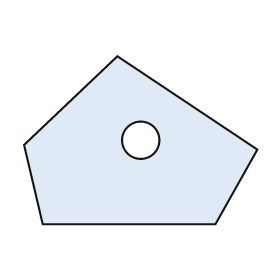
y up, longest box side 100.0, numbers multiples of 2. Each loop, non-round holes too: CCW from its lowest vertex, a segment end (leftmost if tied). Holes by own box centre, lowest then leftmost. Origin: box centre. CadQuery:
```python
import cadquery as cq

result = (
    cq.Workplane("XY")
    .moveTo(-42.0, -36.0)
    .lineTo(32.0, -36.0)
    .lineTo(50.0, -4.0)
    .lineTo(-10.0, 36.0)
    .lineTo(-50.0, -2.0)
    .close()
    .moveTo(0.0, 0.0)
    .circle(8.0)
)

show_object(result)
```